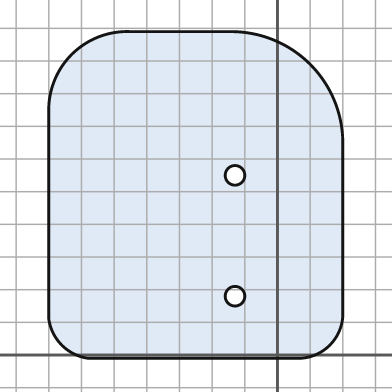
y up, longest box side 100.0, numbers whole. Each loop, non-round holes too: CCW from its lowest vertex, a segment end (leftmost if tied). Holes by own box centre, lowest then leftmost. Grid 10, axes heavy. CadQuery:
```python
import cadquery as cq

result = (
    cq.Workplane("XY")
    .moveTo(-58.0, -1.0)
    .lineTo(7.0, -1.0)
    .threePointArc((16.0, 3.0), (20.0, 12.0))
    .lineTo(20.0, 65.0)
    .threePointArc((10.0, 89.0), (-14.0, 99.0))
    .lineTo(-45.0, 99.0)
    .threePointArc((-63.0, 92.0), (-70.0, 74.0))
    .lineTo(-70.0, 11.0)
    .threePointArc((-66.0, 3.0), (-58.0, -1.0))
    .close()
    .moveTo(-13.0, 18.0)
    .circle(3.0)
    .moveTo(-13.0, 55.0)
    .circle(3.0)
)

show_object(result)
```